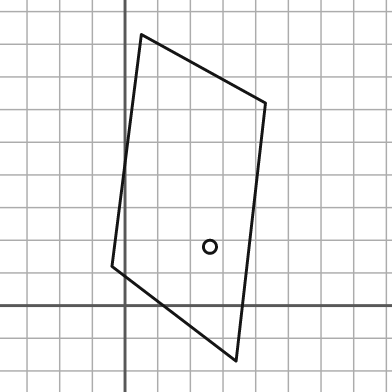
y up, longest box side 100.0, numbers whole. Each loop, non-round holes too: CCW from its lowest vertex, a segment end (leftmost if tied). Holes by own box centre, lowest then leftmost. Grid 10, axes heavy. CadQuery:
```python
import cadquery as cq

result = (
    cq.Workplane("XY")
    .moveTo(34.0, -17.0)
    .lineTo(43.0, 62.0)
    .lineTo(5.0, 83.0)
    .lineTo(-4.0, 12.0)
    .close()
    .moveTo(26.0, 18.0)
    .circle(2.0)
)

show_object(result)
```